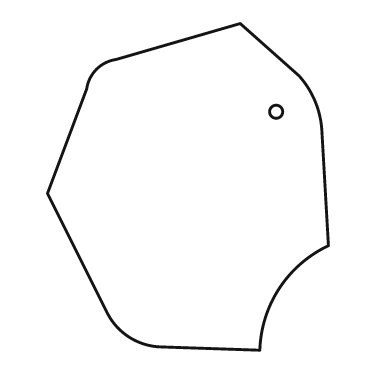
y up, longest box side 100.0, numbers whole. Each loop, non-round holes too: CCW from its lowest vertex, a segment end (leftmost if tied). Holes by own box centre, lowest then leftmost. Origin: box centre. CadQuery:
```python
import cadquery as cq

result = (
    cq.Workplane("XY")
    .moveTo(22.0, -50.0)
    .threePointArc((28.0, -31.0), (43.0, -18.0))
    .lineTo(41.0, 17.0)
    .threePointArc((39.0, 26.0), (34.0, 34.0))
    .lineTo(16.0, 50.0)
    .lineTo(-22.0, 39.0)
    .threePointArc((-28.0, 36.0), (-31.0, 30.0))
    .lineTo(-43.0, -2.0)
    .lineTo(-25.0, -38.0)
    .threePointArc((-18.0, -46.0), (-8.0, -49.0))
    .close()
    .moveTo(27.0, 23.0)
    .circle(2.0)
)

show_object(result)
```